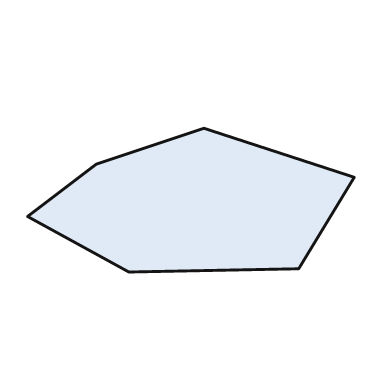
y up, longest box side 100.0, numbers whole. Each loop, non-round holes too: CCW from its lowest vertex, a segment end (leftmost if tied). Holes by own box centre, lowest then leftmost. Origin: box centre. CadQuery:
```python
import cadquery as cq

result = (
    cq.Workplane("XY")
    .moveTo(-19.0, -22.0)
    .lineTo(33.0, -21.0)
    .lineTo(50.0, 7.0)
    .lineTo(4.0, 22.0)
    .lineTo(-29.0, 11.0)
    .lineTo(-50.0, -5.0)
    .close()
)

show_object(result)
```